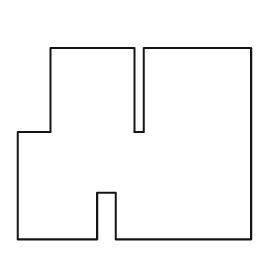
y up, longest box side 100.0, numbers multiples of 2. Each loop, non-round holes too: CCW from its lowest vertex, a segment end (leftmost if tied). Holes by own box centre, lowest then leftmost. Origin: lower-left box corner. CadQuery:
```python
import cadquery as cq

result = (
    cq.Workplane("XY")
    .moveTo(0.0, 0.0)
    .lineTo(34.0, 0.0)
    .lineTo(34.0, 20.0)
    .lineTo(42.0, 20.0)
    .lineTo(42.0, 0.0)
    .lineTo(100.0, 0.0)
    .lineTo(100.0, 82.0)
    .lineTo(54.0, 82.0)
    .lineTo(54.0, 46.0)
    .lineTo(50.0, 46.0)
    .lineTo(50.0, 82.0)
    .lineTo(14.0, 82.0)
    .lineTo(14.0, 46.0)
    .lineTo(0.0, 46.0)
    .close()
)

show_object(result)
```